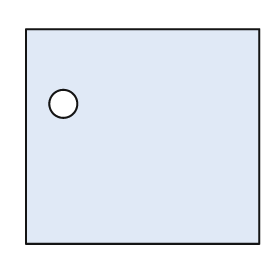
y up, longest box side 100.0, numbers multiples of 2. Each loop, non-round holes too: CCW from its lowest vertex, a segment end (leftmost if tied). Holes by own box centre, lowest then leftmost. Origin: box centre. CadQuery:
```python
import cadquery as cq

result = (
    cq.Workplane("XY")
    .moveTo(-50.0, -46.0)
    .lineTo(50.0, -46.0)
    .lineTo(50.0, 46.0)
    .lineTo(-50.0, 46.0)
    .close()
    .moveTo(-34.0, 14.0)
    .circle(6.0)
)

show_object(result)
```